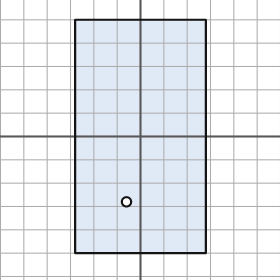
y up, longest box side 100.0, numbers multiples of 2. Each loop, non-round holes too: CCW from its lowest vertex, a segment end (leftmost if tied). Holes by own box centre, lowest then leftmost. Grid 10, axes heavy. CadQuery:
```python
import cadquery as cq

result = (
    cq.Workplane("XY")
    .moveTo(-28.0, -50.0)
    .lineTo(28.0, -50.0)
    .lineTo(28.0, 50.0)
    .lineTo(-28.0, 50.0)
    .close()
    .moveTo(-6.0, -28.0)
    .circle(2.0)
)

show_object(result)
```